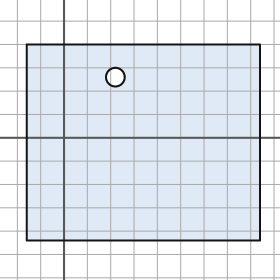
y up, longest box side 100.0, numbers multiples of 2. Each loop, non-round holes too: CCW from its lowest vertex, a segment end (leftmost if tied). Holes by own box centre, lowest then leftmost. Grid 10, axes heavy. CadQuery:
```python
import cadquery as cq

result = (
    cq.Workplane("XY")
    .moveTo(-16.0, -44.0)
    .lineTo(84.0, -44.0)
    .lineTo(84.0, 40.0)
    .lineTo(-16.0, 40.0)
    .close()
    .moveTo(22.0, 26.0)
    .circle(4.0)
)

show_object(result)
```